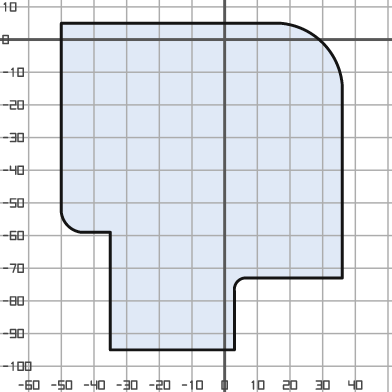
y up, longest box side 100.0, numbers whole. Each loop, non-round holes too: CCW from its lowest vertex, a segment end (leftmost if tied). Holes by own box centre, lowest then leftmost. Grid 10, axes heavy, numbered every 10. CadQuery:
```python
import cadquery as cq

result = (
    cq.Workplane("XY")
    .moveTo(-35.0, -95.0)
    .lineTo(3.0, -95.0)
    .lineTo(3.0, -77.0)
    .threePointArc((4.0, -74.0), (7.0, -73.0))
    .lineTo(36.0, -73.0)
    .lineTo(36.0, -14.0)
    .threePointArc((30.0, -1.0), (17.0, 5.0))
    .lineTo(-50.0, 5.0)
    .lineTo(-50.0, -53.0)
    .threePointArc((-48.0, -57.0), (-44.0, -59.0))
    .lineTo(-35.0, -59.0)
    .close()
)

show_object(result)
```